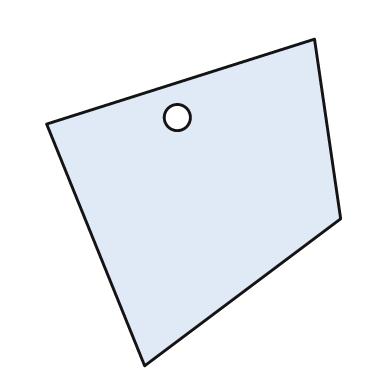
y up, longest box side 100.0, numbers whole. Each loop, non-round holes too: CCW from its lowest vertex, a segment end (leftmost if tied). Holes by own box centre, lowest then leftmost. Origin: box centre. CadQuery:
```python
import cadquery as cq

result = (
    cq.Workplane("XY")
    .moveTo(-15.0, -50.0)
    .lineTo(45.0, -5.0)
    .lineTo(37.0, 50.0)
    .lineTo(-45.0, 24.0)
    .close()
    .moveTo(-5.0, 26.0)
    .circle(4.0)
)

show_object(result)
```